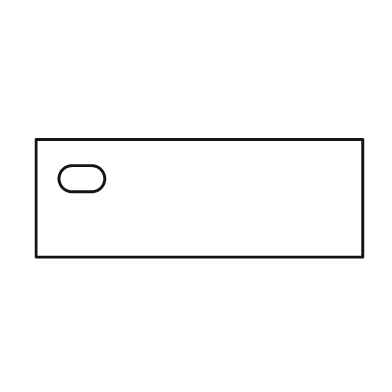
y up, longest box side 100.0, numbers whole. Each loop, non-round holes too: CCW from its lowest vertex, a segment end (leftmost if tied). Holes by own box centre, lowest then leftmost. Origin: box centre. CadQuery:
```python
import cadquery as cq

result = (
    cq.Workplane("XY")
    .moveTo(-50.0, -18.0)
    .lineTo(50.0, -18.0)
    .lineTo(50.0, 18.0)
    .lineTo(-50.0, 18.0)
    .close()
    .moveTo(-39.0, 2.0)
    .lineTo(-33.0, 2.0)
    .threePointArc((-29.0, 6.0), (-33.0, 10.0))
    .lineTo(-39.0, 10.0)
    .threePointArc((-43.0, 6.0), (-39.0, 2.0))
    .close()
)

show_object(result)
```